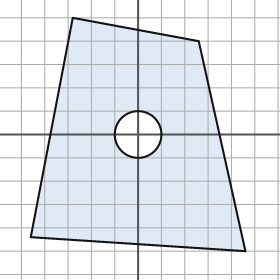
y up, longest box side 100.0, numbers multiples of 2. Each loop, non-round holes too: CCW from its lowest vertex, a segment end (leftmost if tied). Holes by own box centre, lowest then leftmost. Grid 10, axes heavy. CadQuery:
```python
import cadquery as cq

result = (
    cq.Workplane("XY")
    .moveTo(46.0, -50.0)
    .lineTo(26.0, 40.0)
    .lineTo(-28.0, 50.0)
    .lineTo(-46.0, -44.0)
    .close()
    .moveTo(0.0, 0.0)
    .circle(10.0)
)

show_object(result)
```